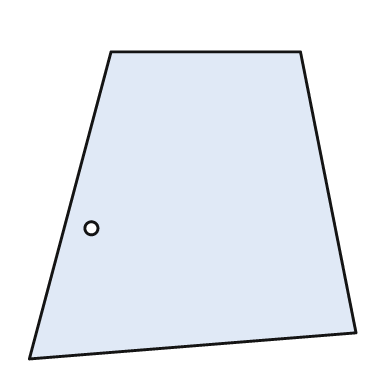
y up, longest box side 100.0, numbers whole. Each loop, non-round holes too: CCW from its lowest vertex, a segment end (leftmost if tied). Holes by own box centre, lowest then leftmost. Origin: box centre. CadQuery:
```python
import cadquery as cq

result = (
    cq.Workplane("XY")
    .moveTo(-50.0, -47.0)
    .lineTo(50.0, -39.0)
    .lineTo(33.0, 47.0)
    .lineTo(-25.0, 47.0)
    .close()
    .moveTo(-31.0, -7.0)
    .circle(2.0)
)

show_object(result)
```